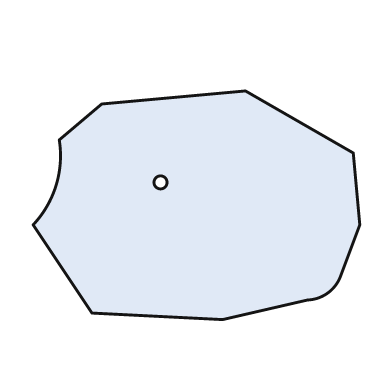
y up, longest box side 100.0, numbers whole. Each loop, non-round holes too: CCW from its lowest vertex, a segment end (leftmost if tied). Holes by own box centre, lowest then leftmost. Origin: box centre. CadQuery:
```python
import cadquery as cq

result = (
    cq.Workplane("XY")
    .moveTo(8.0, -35.0)
    .lineTo(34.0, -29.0)
    .threePointArc((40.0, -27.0), (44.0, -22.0))
    .lineTo(50.0, -6.0)
    .lineTo(48.0, 16.0)
    .lineTo(15.0, 35.0)
    .lineTo(-29.0, 31.0)
    .lineTo(-42.0, 20.0)
    .threePointArc((-43.0, 6.0), (-50.0, -6.0))
    .lineTo(-32.0, -33.0)
    .close()
    .moveTo(-11.0, 7.0)
    .circle(2.0)
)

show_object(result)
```